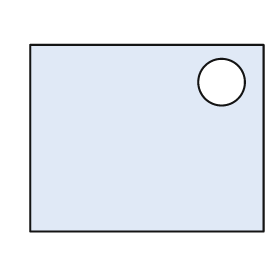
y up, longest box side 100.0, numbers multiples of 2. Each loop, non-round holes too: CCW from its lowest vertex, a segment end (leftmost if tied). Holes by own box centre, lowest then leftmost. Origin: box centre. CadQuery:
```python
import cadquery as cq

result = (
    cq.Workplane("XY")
    .moveTo(-50.0, -40.0)
    .lineTo(50.0, -40.0)
    .lineTo(50.0, 40.0)
    .lineTo(-50.0, 40.0)
    .close()
    .moveTo(32.0, 24.0)
    .circle(10.0)
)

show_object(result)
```